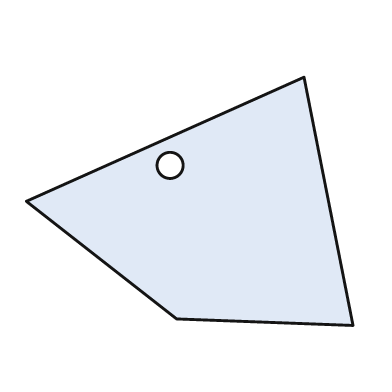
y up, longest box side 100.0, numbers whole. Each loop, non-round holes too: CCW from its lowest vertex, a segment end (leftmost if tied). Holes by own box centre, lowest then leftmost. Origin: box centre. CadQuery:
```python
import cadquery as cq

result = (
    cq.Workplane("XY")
    .moveTo(50.0, -38.0)
    .lineTo(35.0, 38.0)
    .lineTo(-50.0, 0.0)
    .lineTo(-4.0, -36.0)
    .close()
    .moveTo(-6.0, 11.0)
    .circle(4.0)
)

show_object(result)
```